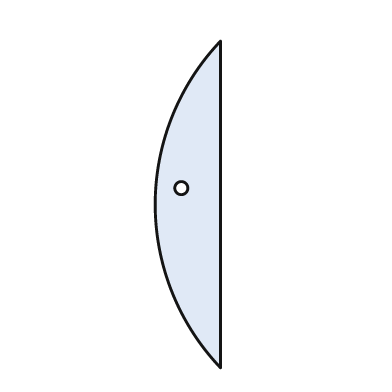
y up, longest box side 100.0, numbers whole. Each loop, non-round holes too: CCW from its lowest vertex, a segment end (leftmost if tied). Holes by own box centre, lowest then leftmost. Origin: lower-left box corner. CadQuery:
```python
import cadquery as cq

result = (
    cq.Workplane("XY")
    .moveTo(20.0, 0.0)
    .lineTo(20.0, 100.0)
    .threePointArc((0.0, 50.0), (20.0, 0.0))
    .close()
    .moveTo(8.0, 55.0)
    .circle(2.0)
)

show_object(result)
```